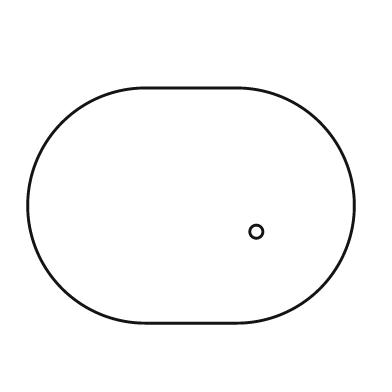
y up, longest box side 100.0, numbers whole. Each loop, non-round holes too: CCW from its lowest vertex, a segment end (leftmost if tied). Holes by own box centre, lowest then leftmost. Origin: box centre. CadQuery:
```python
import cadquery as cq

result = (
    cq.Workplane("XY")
    .moveTo(-14.0, -36.0)
    .lineTo(14.0, -36.0)
    .threePointArc((50.0, 0.0), (14.0, 36.0))
    .lineTo(-14.0, 36.0)
    .threePointArc((-50.0, 0.0), (-14.0, -36.0))
    .close()
    .moveTo(20.0, -8.0)
    .circle(2.0)
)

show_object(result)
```